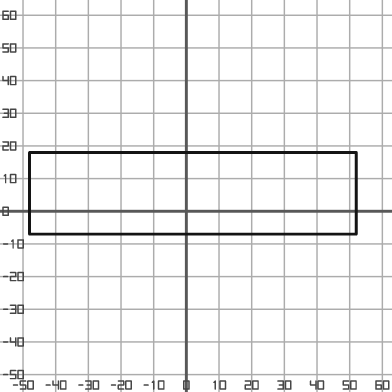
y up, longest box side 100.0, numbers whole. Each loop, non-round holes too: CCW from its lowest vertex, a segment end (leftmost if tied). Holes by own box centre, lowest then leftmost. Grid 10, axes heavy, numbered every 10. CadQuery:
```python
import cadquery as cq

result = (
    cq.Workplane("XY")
    .moveTo(-48.0, -7.0)
    .lineTo(52.0, -7.0)
    .lineTo(52.0, 18.0)
    .lineTo(-48.0, 18.0)
    .close()
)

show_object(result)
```